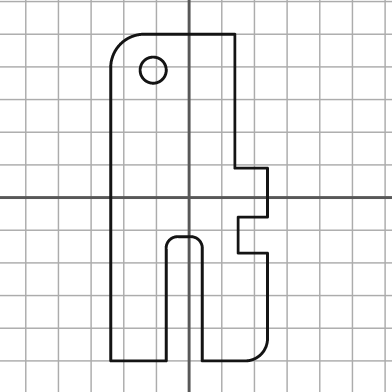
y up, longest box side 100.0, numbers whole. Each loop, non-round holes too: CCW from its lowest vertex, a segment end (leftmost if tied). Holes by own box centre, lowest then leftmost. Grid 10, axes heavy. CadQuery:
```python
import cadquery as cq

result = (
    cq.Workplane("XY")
    .moveTo(-24.0, -50.0)
    .lineTo(-7.0, -50.0)
    .lineTo(-7.0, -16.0)
    .threePointArc((-6.0, -13.0), (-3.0, -12.0))
    .lineTo(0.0, -12.0)
    .threePointArc((3.0, -13.0), (4.0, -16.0))
    .lineTo(4.0, -50.0)
    .lineTo(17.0, -50.0)
    .threePointArc((22.0, -48.0), (24.0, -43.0))
    .lineTo(24.0, -17.0)
    .lineTo(15.0, -17.0)
    .lineTo(15.0, -6.0)
    .lineTo(24.0, -6.0)
    .lineTo(24.0, 9.0)
    .lineTo(14.0, 9.0)
    .lineTo(14.0, 50.0)
    .lineTo(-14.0, 50.0)
    .threePointArc((-21.0, 47.0), (-24.0, 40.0))
    .close()
    .moveTo(-11.0, 39.0)
    .circle(4.0)
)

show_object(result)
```